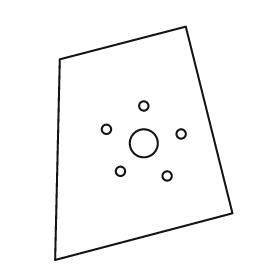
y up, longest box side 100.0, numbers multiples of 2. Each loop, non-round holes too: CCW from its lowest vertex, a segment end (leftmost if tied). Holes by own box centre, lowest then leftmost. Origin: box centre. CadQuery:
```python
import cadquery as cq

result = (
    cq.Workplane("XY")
    .moveTo(-38.0, -50.0)
    .lineTo(38.0, -30.0)
    .lineTo(18.0, 50.0)
    .lineTo(-36.0, 36.0)
    .close()
    .moveTo(10.0, -14.0)
    .circle(2.0)
    .moveTo(-10.0, -12.0)
    .circle(2.0)
    .moveTo(0.0, 0.0)
    .circle(6.0)
    .moveTo(16.0, 4.0)
    .circle(2.0)
    .moveTo(-16.0, 6.0)
    .circle(2.0)
    .moveTo(0.0, 16.0)
    .circle(2.0)
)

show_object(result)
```